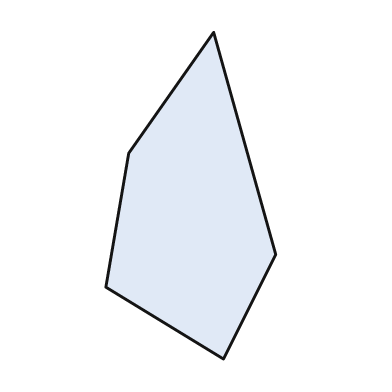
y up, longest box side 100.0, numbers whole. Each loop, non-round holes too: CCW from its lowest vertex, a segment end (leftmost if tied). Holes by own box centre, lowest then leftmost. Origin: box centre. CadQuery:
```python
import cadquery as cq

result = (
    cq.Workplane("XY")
    .moveTo(10.0, -50.0)
    .lineTo(26.0, -18.0)
    .lineTo(7.0, 50.0)
    .lineTo(-19.0, 13.0)
    .lineTo(-26.0, -28.0)
    .close()
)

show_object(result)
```